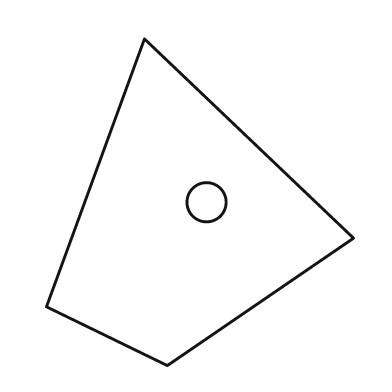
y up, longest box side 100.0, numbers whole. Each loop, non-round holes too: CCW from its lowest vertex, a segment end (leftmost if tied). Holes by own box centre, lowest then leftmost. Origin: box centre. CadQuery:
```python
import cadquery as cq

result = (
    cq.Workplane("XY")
    .moveTo(-10.0, -50.0)
    .lineTo(47.0, -11.0)
    .lineTo(-17.0, 50.0)
    .lineTo(-47.0, -32.0)
    .close()
    .moveTo(2.0, 0.0)
    .circle(6.0)
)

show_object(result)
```